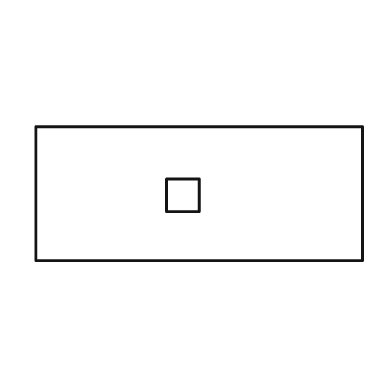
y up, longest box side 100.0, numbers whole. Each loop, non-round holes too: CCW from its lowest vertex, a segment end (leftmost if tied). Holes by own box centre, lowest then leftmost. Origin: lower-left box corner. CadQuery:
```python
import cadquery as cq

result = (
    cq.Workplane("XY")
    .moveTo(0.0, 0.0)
    .lineTo(100.0, 0.0)
    .lineTo(100.0, 41.0)
    .lineTo(0.0, 41.0)
    .close()
    .moveTo(40.0, 15.0)
    .lineTo(50.0, 15.0)
    .lineTo(50.0, 25.0)
    .lineTo(40.0, 25.0)
    .close()
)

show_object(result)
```